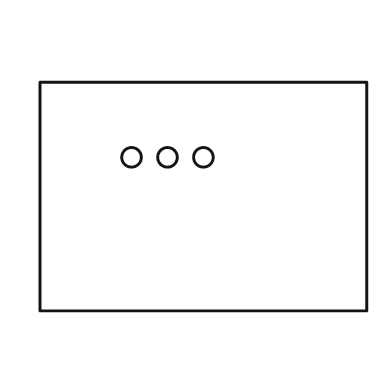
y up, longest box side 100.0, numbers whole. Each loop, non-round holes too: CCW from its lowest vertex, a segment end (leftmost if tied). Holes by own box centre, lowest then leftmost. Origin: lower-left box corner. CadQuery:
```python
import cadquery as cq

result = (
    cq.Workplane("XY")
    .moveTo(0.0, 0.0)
    .lineTo(100.0, 0.0)
    .lineTo(100.0, 70.0)
    .lineTo(0.0, 70.0)
    .close()
    .moveTo(28.0, 47.0)
    .circle(3.0)
    .moveTo(39.0, 47.0)
    .circle(3.0)
    .moveTo(50.0, 47.0)
    .circle(3.0)
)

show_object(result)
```